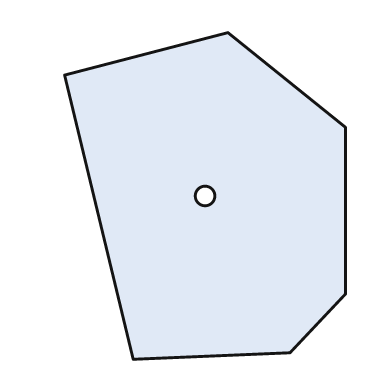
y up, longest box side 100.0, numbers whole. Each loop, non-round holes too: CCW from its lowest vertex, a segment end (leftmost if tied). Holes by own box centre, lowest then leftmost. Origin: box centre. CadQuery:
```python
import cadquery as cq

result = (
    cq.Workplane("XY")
    .moveTo(-22.0, -50.0)
    .lineTo(26.0, -48.0)
    .lineTo(43.0, -30.0)
    .lineTo(43.0, 21.0)
    .lineTo(7.0, 50.0)
    .lineTo(-43.0, 37.0)
    .close()
    .moveTo(0.0, 0.0)
    .circle(3.0)
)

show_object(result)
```